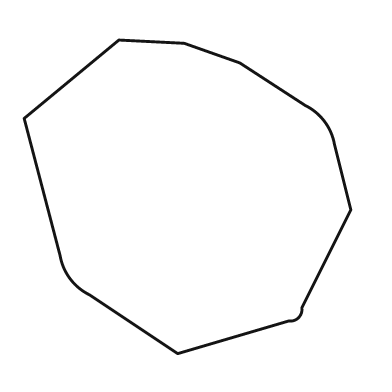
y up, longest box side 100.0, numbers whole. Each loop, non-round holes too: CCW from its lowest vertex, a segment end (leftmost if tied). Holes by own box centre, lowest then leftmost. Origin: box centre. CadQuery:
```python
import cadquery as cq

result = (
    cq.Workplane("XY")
    .moveTo(-3.0, -48.0)
    .lineTo(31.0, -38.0)
    .threePointArc((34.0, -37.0), (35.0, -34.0))
    .lineTo(50.0, -4.0)
    .lineTo(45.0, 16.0)
    .threePointArc((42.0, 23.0), (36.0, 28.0))
    .lineTo(16.0, 41.0)
    .lineTo(-1.0, 47.0)
    .lineTo(-21.0, 48.0)
    .lineTo(-50.0, 24.0)
    .lineTo(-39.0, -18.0)
    .threePointArc((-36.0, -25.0), (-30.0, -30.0))
    .close()
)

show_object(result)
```